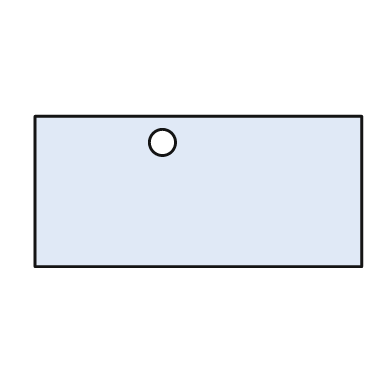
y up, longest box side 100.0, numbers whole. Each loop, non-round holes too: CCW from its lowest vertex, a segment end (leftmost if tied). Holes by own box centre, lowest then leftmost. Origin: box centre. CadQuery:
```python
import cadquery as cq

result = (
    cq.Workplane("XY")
    .moveTo(-50.0, -23.0)
    .lineTo(50.0, -23.0)
    .lineTo(50.0, 23.0)
    .lineTo(-50.0, 23.0)
    .close()
    .moveTo(-11.0, 15.0)
    .circle(4.0)
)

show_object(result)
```